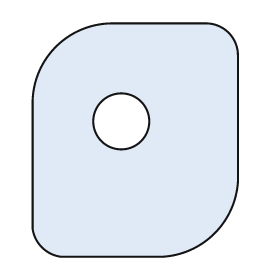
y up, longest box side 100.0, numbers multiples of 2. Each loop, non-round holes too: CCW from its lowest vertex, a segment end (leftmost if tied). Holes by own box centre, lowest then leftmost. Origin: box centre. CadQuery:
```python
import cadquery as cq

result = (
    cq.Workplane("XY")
    .moveTo(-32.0, -50.0)
    .lineTo(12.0, -50.0)
    .threePointArc((34.0, -40.0), (44.0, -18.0))
    .lineTo(44.0, 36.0)
    .threePointArc((40.0, 46.0), (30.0, 50.0))
    .lineTo(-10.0, 50.0)
    .threePointArc((-34.0, 40.0), (-44.0, 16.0))
    .lineTo(-44.0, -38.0)
    .threePointArc((-40.0, -46.0), (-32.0, -50.0))
    .close()
    .moveTo(-6.0, 8.0)
    .circle(12.0)
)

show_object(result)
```